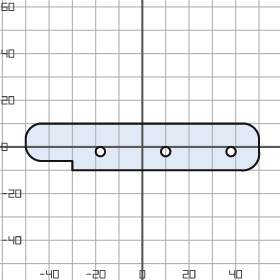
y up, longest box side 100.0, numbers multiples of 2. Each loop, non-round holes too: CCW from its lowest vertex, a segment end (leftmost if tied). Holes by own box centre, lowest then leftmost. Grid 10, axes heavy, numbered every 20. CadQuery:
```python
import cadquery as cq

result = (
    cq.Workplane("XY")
    .moveTo(-30.0, -10.0)
    .lineTo(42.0, -10.0)
    .threePointArc((48.0, -8.0), (50.0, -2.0))
    .lineTo(50.0, 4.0)
    .threePointArc((48.0, 8.0), (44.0, 10.0))
    .lineTo(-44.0, 10.0)
    .threePointArc((-48.0, 8.0), (-50.0, 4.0))
    .lineTo(-50.0, 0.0)
    .threePointArc((-48.0, -4.0), (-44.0, -6.0))
    .lineTo(-30.0, -6.0)
    .close()
    .moveTo(-18.0, -2.0)
    .circle(2.0)
    .moveTo(10.0, -2.0)
    .circle(2.0)
    .moveTo(38.0, -2.0)
    .circle(2.0)
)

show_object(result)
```